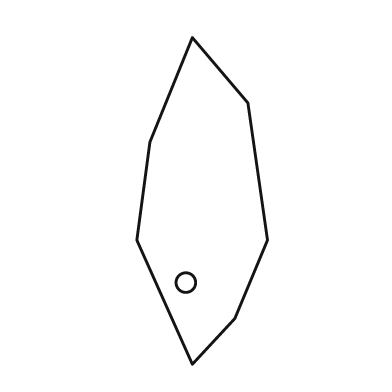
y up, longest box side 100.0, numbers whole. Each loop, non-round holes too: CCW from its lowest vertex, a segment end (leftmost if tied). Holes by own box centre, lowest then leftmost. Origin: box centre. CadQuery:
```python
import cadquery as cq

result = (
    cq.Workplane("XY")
    .moveTo(-3.0, -50.0)
    .lineTo(10.0, -36.0)
    .lineTo(20.0, -12.0)
    .lineTo(14.0, 30.0)
    .lineTo(-3.0, 50.0)
    .lineTo(-16.0, 18.0)
    .lineTo(-20.0, -12.0)
    .close()
    .moveTo(-5.0, -25.0)
    .circle(3.0)
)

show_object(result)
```